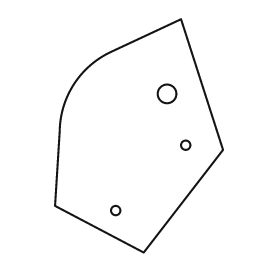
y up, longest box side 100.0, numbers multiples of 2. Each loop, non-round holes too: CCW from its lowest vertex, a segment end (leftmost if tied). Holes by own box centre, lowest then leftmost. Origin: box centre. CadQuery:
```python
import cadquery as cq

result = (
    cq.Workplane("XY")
    .moveTo(2.0, -50.0)
    .lineTo(36.0, -6.0)
    .lineTo(18.0, 50.0)
    .lineTo(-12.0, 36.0)
    .threePointArc((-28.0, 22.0), (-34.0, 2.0))
    .lineTo(-36.0, -30.0)
    .close()
    .moveTo(-10.0, -32.0)
    .circle(2.0)
    .moveTo(20.0, -4.0)
    .circle(2.0)
    .moveTo(12.0, 18.0)
    .circle(4.0)
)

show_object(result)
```